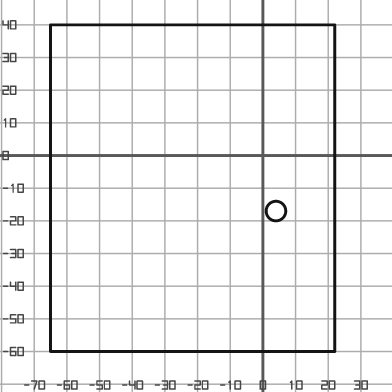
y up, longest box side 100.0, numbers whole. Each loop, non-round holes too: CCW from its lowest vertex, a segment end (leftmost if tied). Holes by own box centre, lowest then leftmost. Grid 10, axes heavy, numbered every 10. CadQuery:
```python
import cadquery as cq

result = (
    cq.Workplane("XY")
    .moveTo(-65.0, -60.0)
    .lineTo(22.0, -60.0)
    .lineTo(22.0, 40.0)
    .lineTo(-65.0, 40.0)
    .close()
    .moveTo(4.0, -17.0)
    .circle(3.0)
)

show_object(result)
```